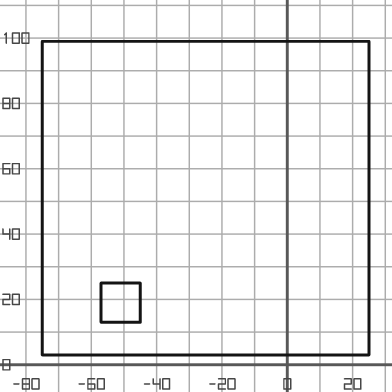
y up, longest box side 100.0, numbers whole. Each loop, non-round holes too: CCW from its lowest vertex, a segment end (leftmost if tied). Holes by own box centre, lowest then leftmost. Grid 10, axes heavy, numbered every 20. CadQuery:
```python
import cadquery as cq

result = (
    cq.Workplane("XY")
    .moveTo(-75.0, 3.0)
    .lineTo(25.0, 3.0)
    .lineTo(25.0, 99.0)
    .lineTo(-75.0, 99.0)
    .close()
    .moveTo(-57.0, 13.0)
    .lineTo(-45.0, 13.0)
    .lineTo(-45.0, 25.0)
    .lineTo(-57.0, 25.0)
    .close()
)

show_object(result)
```